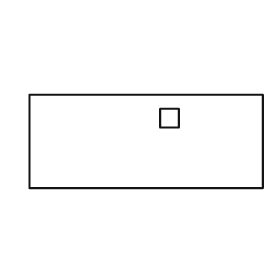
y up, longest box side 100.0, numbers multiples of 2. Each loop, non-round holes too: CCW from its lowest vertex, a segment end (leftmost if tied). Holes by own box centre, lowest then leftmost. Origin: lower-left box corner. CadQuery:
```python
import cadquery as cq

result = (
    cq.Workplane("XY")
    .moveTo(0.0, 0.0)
    .lineTo(100.0, 0.0)
    .lineTo(100.0, 40.0)
    .lineTo(0.0, 40.0)
    .close()
    .moveTo(56.0, 26.0)
    .lineTo(64.0, 26.0)
    .lineTo(64.0, 34.0)
    .lineTo(56.0, 34.0)
    .close()
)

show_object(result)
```